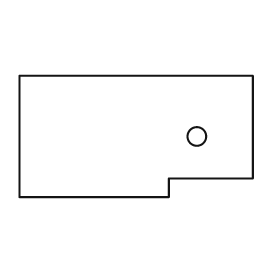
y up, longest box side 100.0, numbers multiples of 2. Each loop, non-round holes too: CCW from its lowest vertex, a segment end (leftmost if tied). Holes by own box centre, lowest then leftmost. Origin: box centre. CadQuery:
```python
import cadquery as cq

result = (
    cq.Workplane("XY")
    .moveTo(-50.0, -26.0)
    .lineTo(14.0, -26.0)
    .lineTo(14.0, -18.0)
    .lineTo(50.0, -18.0)
    .lineTo(50.0, 26.0)
    .lineTo(-50.0, 26.0)
    .close()
    .moveTo(26.0, 0.0)
    .circle(4.0)
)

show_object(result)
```